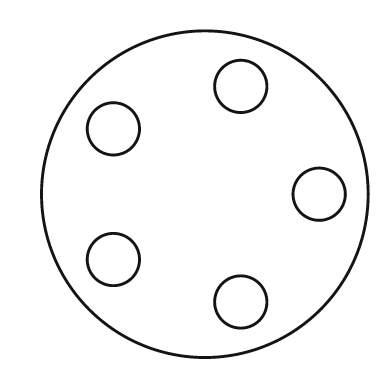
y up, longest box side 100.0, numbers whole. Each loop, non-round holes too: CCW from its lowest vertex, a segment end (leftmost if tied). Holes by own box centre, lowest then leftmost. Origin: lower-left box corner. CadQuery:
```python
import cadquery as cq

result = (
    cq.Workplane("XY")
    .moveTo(50.0, 50.0)
    .circle(50.0)
    .moveTo(61.0, 17.0)
    .circle(8.0)
    .moveTo(22.0, 30.0)
    .circle(8.0)
    .moveTo(85.0, 50.0)
    .circle(8.0)
    .moveTo(22.0, 70.0)
    .circle(8.0)
    .moveTo(61.0, 83.0)
    .circle(8.0)
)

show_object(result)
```